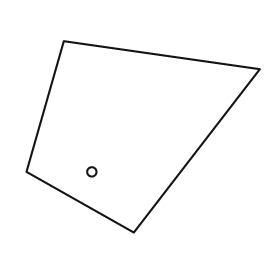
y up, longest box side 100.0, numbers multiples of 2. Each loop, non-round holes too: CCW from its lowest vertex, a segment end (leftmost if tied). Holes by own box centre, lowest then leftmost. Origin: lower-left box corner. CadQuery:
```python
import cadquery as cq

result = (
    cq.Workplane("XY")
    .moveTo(46.0, 0.0)
    .lineTo(100.0, 70.0)
    .lineTo(16.0, 82.0)
    .lineTo(0.0, 26.0)
    .close()
    .moveTo(28.0, 26.0)
    .circle(2.0)
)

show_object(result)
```